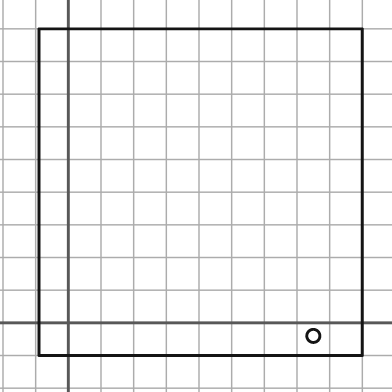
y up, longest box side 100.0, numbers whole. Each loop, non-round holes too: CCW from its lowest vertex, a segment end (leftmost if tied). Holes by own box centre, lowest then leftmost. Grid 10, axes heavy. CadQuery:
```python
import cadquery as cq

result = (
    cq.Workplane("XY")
    .moveTo(-9.0, -10.0)
    .lineTo(90.0, -10.0)
    .lineTo(90.0, 90.0)
    .lineTo(-9.0, 90.0)
    .close()
    .moveTo(75.0, -4.0)
    .circle(2.0)
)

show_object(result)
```